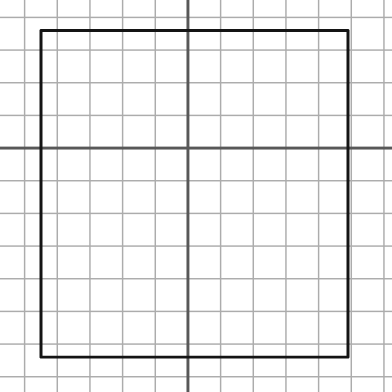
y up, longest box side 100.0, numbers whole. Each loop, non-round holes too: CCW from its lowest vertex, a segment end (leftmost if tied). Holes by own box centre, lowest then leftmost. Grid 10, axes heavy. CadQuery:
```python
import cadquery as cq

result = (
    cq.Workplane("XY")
    .moveTo(-45.0, -64.0)
    .lineTo(49.0, -64.0)
    .lineTo(49.0, 36.0)
    .lineTo(-45.0, 36.0)
    .close()
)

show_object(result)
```